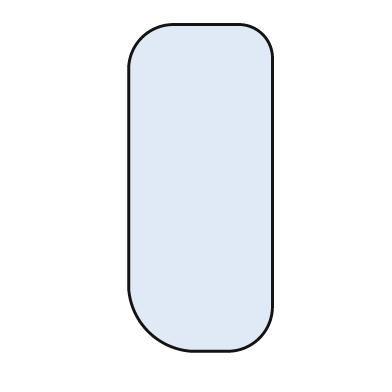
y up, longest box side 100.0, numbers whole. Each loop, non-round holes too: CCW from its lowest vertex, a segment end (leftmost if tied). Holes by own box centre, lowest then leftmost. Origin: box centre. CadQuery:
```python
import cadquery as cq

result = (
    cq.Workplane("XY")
    .moveTo(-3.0, -50.0)
    .lineTo(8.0, -50.0)
    .threePointArc((18.0, -46.0), (22.0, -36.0))
    .lineTo(22.0, 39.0)
    .threePointArc((19.0, 47.0), (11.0, 50.0))
    .lineTo(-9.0, 50.0)
    .threePointArc((-18.0, 46.0), (-22.0, 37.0))
    .lineTo(-22.0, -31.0)
    .threePointArc((-16.0, -44.0), (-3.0, -50.0))
    .close()
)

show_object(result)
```